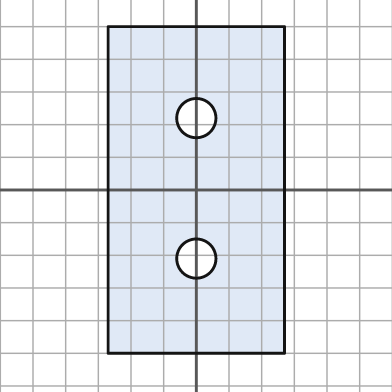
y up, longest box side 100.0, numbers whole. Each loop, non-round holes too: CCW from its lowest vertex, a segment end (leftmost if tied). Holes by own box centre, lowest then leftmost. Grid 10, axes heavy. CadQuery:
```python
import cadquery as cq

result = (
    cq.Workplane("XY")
    .moveTo(-27.0, -50.0)
    .lineTo(27.0, -50.0)
    .lineTo(27.0, 50.0)
    .lineTo(-27.0, 50.0)
    .close()
    .moveTo(0.0, -21.0)
    .circle(6.0)
    .moveTo(0.0, 22.0)
    .circle(6.0)
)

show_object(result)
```